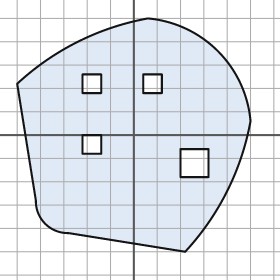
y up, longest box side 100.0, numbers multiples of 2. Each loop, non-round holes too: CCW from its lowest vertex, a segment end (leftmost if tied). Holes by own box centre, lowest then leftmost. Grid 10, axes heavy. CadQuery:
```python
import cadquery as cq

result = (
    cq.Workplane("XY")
    .moveTo(22.0, -50.0)
    .threePointArc((40.0, -24.0), (50.0, 6.0))
    .threePointArc((36.0, 36.0), (6.0, 50.0))
    .threePointArc((-24.0, 40.0), (-50.0, 22.0))
    .lineTo(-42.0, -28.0)
    .threePointArc((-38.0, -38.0), (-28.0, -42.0))
    .close()
    .moveTo(20.0, -18.0)
    .lineTo(32.0, -18.0)
    .lineTo(32.0, -6.0)
    .lineTo(20.0, -6.0)
    .close()
    .moveTo(-22.0, -8.0)
    .lineTo(-14.0, -8.0)
    .lineTo(-14.0, 0.0)
    .lineTo(-22.0, 0.0)
    .close()
    .moveTo(-22.0, 18.0)
    .lineTo(-14.0, 18.0)
    .lineTo(-14.0, 26.0)
    .lineTo(-22.0, 26.0)
    .close()
    .moveTo(4.0, 18.0)
    .lineTo(12.0, 18.0)
    .lineTo(12.0, 26.0)
    .lineTo(4.0, 26.0)
    .close()
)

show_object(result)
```